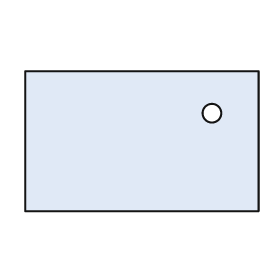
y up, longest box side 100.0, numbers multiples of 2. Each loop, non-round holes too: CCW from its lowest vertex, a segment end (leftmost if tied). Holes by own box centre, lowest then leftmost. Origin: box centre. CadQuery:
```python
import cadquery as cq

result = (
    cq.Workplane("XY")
    .moveTo(-50.0, -30.0)
    .lineTo(50.0, -30.0)
    .lineTo(50.0, 30.0)
    .lineTo(-50.0, 30.0)
    .close()
    .moveTo(30.0, 12.0)
    .circle(4.0)
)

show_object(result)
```